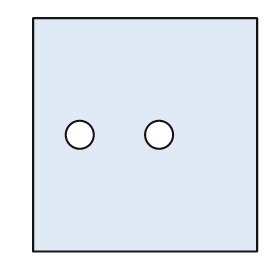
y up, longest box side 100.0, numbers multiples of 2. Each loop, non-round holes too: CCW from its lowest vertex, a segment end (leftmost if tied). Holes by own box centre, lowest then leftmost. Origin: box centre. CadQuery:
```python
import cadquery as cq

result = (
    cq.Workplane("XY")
    .moveTo(-48.0, -50.0)
    .lineTo(48.0, -50.0)
    .lineTo(48.0, 50.0)
    .lineTo(-48.0, 50.0)
    .close()
    .moveTo(-28.0, 0.0)
    .circle(6.0)
    .moveTo(6.0, 0.0)
    .circle(6.0)
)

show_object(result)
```